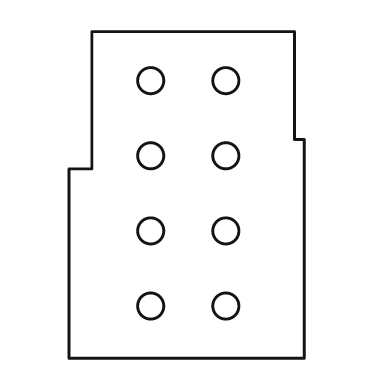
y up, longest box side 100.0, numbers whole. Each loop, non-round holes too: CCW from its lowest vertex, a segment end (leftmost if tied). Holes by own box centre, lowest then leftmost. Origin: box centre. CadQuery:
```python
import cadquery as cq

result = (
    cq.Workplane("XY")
    .moveTo(-36.0, -50.0)
    .lineTo(36.0, -50.0)
    .lineTo(36.0, 17.0)
    .lineTo(33.0, 17.0)
    .lineTo(33.0, 50.0)
    .lineTo(-29.0, 50.0)
    .lineTo(-29.0, 8.0)
    .lineTo(-36.0, 8.0)
    .close()
    .moveTo(-11.0, -34.0)
    .circle(4.0)
    .moveTo(12.0, -34.0)
    .circle(4.0)
    .moveTo(-11.0, -11.0)
    .circle(4.0)
    .moveTo(12.0, -11.0)
    .circle(4.0)
    .moveTo(-11.0, 12.0)
    .circle(4.0)
    .moveTo(12.0, 12.0)
    .circle(4.0)
    .moveTo(-11.0, 35.0)
    .circle(4.0)
    .moveTo(12.0, 35.0)
    .circle(4.0)
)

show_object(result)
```